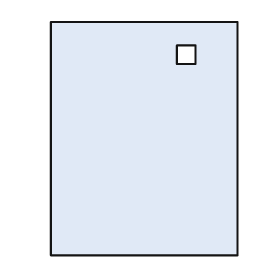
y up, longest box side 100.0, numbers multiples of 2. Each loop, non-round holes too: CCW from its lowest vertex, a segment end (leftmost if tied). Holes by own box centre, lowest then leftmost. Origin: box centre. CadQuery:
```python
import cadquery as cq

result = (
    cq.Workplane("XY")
    .moveTo(-40.0, -50.0)
    .lineTo(40.0, -50.0)
    .lineTo(40.0, 50.0)
    .lineTo(-40.0, 50.0)
    .close()
    .moveTo(14.0, 32.0)
    .lineTo(22.0, 32.0)
    .lineTo(22.0, 40.0)
    .lineTo(14.0, 40.0)
    .close()
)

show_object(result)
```